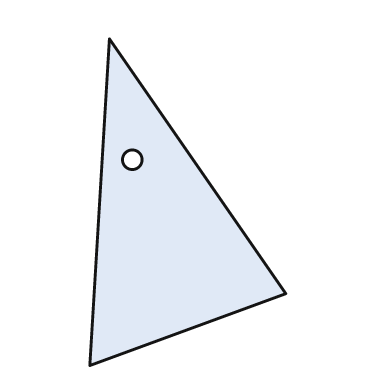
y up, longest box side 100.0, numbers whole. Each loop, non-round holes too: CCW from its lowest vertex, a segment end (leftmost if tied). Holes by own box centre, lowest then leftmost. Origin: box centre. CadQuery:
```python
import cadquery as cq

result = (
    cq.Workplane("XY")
    .moveTo(-30.0, -50.0)
    .lineTo(30.0, -28.0)
    .lineTo(-24.0, 50.0)
    .close()
    .moveTo(-17.0, 13.0)
    .circle(3.0)
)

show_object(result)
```